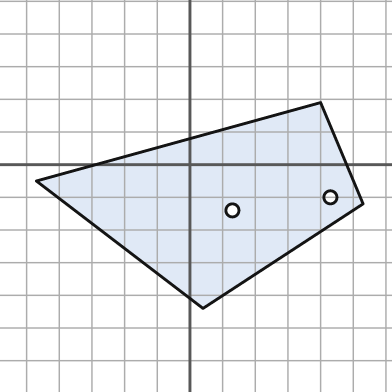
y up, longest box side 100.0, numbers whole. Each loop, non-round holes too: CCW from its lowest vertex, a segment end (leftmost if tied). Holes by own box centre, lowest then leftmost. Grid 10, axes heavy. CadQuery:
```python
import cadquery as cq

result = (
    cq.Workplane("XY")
    .moveTo(4.0, -44.0)
    .lineTo(53.0, -12.0)
    .lineTo(40.0, 19.0)
    .lineTo(-47.0, -5.0)
    .close()
    .moveTo(13.0, -14.0)
    .circle(2.0)
    .moveTo(43.0, -10.0)
    .circle(2.0)
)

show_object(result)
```